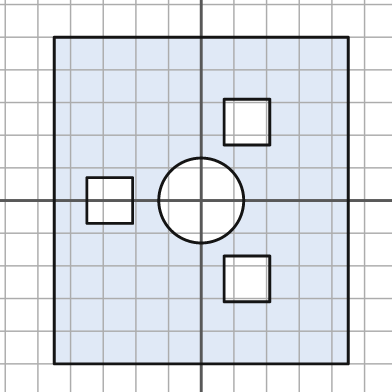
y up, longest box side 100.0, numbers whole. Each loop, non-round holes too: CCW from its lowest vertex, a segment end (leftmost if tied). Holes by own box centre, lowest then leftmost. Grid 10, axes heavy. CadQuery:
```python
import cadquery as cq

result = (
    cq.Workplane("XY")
    .moveTo(-45.0, -50.0)
    .lineTo(45.0, -50.0)
    .lineTo(45.0, 50.0)
    .lineTo(-45.0, 50.0)
    .close()
    .moveTo(7.0, -31.0)
    .lineTo(21.0, -31.0)
    .lineTo(21.0, -17.0)
    .lineTo(7.0, -17.0)
    .close()
    .moveTo(-35.0, -7.0)
    .lineTo(-21.0, -7.0)
    .lineTo(-21.0, 7.0)
    .lineTo(-35.0, 7.0)
    .close()
    .moveTo(0.0, 0.0)
    .circle(13.0)
    .moveTo(7.0, 17.0)
    .lineTo(21.0, 17.0)
    .lineTo(21.0, 31.0)
    .lineTo(7.0, 31.0)
    .close()
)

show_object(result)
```